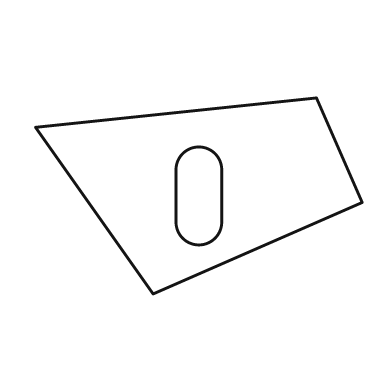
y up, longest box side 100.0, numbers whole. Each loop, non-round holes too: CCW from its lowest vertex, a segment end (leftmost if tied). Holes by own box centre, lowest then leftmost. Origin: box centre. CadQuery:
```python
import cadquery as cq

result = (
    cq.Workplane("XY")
    .moveTo(-14.0, -30.0)
    .lineTo(50.0, -2.0)
    .lineTo(36.0, 30.0)
    .lineTo(-50.0, 21.0)
    .close()
    .moveTo(-7.0, -8.0)
    .threePointArc((0.0, -15.0), (7.0, -8.0))
    .lineTo(7.0, 8.0)
    .threePointArc((0.0, 15.0), (-7.0, 8.0))
    .close()
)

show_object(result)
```